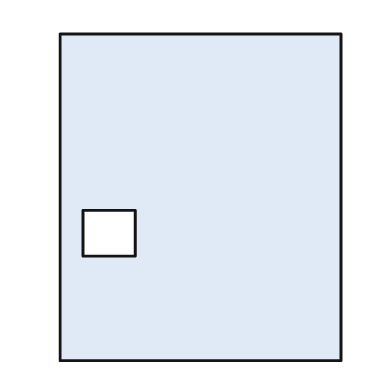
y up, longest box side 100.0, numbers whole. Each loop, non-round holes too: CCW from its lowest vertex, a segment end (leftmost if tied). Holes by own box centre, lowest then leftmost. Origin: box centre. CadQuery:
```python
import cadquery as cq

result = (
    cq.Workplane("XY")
    .moveTo(-43.0, -50.0)
    .lineTo(43.0, -50.0)
    .lineTo(43.0, 50.0)
    .lineTo(-43.0, 50.0)
    .close()
    .moveTo(-36.0, -18.0)
    .lineTo(-20.0, -18.0)
    .lineTo(-20.0, -4.0)
    .lineTo(-36.0, -4.0)
    .close()
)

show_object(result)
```